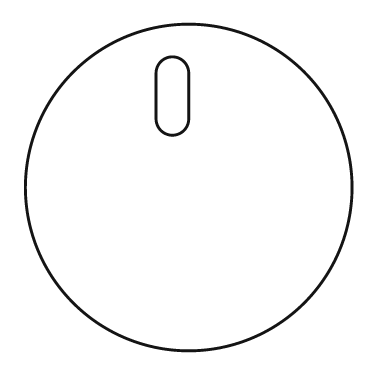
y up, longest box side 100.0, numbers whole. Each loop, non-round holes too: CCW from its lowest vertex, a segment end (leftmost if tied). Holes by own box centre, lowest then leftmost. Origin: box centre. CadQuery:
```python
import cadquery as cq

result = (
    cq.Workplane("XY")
    .moveTo(0.0, 0.0)
    .circle(50.0)
    .moveTo(-10.0, 21.0)
    .threePointArc((-5.0, 16.0), (0.0, 21.0))
    .lineTo(0.0, 35.0)
    .threePointArc((-5.0, 40.0), (-10.0, 35.0))
    .close()
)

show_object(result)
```